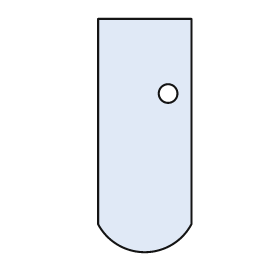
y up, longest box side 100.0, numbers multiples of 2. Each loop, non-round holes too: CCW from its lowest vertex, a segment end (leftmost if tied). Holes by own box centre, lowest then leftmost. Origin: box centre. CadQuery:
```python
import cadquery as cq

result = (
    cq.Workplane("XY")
    .moveTo(-20.0, -38.0)
    .threePointArc((0.0, -50.0), (20.0, -38.0))
    .lineTo(20.0, 50.0)
    .lineTo(-20.0, 50.0)
    .close()
    .moveTo(10.0, 18.0)
    .circle(4.0)
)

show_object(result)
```